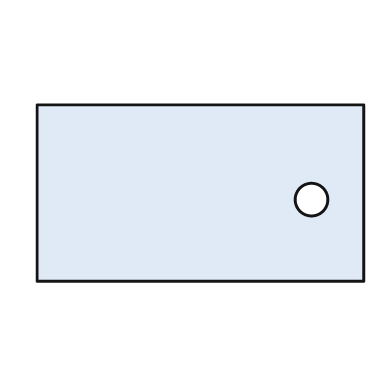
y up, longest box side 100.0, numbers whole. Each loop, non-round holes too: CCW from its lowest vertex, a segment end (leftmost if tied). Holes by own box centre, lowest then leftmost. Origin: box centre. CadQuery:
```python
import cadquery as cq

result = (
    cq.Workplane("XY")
    .moveTo(-50.0, -27.0)
    .lineTo(50.0, -27.0)
    .lineTo(50.0, 27.0)
    .lineTo(-50.0, 27.0)
    .close()
    .moveTo(34.0, -2.0)
    .circle(5.0)
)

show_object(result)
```